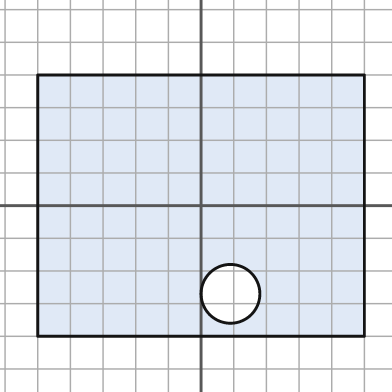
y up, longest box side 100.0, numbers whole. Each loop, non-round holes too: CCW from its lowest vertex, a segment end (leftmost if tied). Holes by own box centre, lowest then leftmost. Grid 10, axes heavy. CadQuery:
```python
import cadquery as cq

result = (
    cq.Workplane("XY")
    .moveTo(-50.0, -40.0)
    .lineTo(50.0, -40.0)
    .lineTo(50.0, 40.0)
    .lineTo(-50.0, 40.0)
    .close()
    .moveTo(9.0, -27.0)
    .circle(9.0)
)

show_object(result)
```